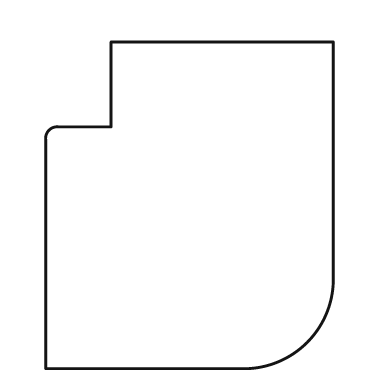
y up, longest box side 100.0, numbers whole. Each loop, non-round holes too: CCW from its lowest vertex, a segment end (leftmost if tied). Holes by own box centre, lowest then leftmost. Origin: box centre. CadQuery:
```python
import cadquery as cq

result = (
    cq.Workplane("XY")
    .moveTo(-44.0, -50.0)
    .lineTo(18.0, -50.0)
    .threePointArc((36.0, -42.0), (44.0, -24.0))
    .lineTo(44.0, 50.0)
    .lineTo(-24.0, 50.0)
    .lineTo(-24.0, 24.0)
    .lineTo(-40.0, 24.0)
    .threePointArc((-43.0, 23.0), (-44.0, 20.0))
    .close()
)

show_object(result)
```